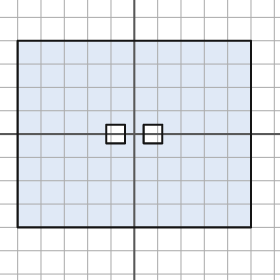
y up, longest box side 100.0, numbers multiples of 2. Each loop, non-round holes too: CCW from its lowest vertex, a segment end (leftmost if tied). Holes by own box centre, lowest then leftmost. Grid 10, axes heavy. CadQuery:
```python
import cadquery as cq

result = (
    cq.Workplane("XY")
    .moveTo(-50.0, -40.0)
    .lineTo(50.0, -40.0)
    .lineTo(50.0, 40.0)
    .lineTo(-50.0, 40.0)
    .close()
    .moveTo(-12.0, -4.0)
    .lineTo(-4.0, -4.0)
    .lineTo(-4.0, 4.0)
    .lineTo(-12.0, 4.0)
    .close()
    .moveTo(4.0, -4.0)
    .lineTo(12.0, -4.0)
    .lineTo(12.0, 4.0)
    .lineTo(4.0, 4.0)
    .close()
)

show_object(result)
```